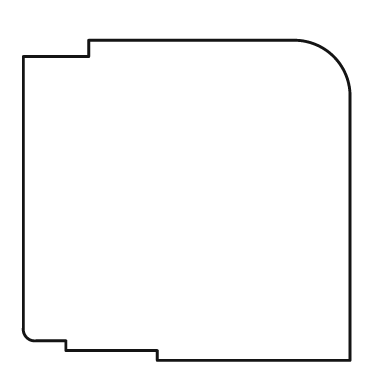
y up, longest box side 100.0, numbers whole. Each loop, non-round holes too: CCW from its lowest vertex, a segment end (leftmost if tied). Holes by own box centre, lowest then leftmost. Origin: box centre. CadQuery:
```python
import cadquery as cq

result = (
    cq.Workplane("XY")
    .moveTo(-9.0, -49.0)
    .lineTo(50.0, -49.0)
    .lineTo(50.0, 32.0)
    .threePointArc((45.0, 44.0), (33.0, 49.0))
    .lineTo(-30.0, 49.0)
    .lineTo(-30.0, 44.0)
    .lineTo(-50.0, 44.0)
    .lineTo(-50.0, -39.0)
    .threePointArc((-49.0, -42.0), (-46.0, -43.0))
    .lineTo(-37.0, -43.0)
    .lineTo(-37.0, -46.0)
    .lineTo(-9.0, -46.0)
    .close()
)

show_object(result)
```